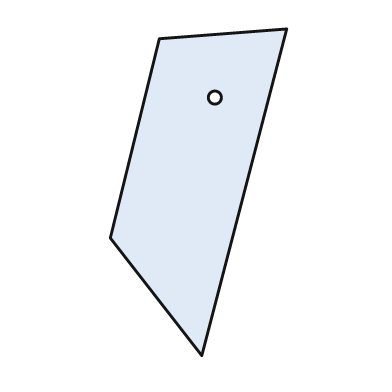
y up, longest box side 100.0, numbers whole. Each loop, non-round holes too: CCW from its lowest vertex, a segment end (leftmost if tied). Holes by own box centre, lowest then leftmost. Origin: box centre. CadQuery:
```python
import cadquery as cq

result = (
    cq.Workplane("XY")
    .moveTo(1.0, -50.0)
    .lineTo(27.0, 50.0)
    .lineTo(-12.0, 47.0)
    .lineTo(-27.0, -14.0)
    .close()
    .moveTo(5.0, 29.0)
    .circle(2.0)
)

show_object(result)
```